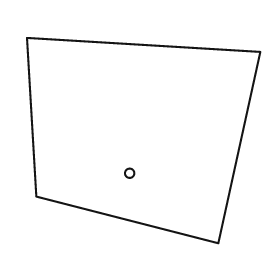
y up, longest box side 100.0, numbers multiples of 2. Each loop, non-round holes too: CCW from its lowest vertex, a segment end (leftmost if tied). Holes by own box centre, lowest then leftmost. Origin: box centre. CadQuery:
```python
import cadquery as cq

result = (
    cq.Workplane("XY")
    .moveTo(32.0, -44.0)
    .lineTo(50.0, 38.0)
    .lineTo(-50.0, 44.0)
    .lineTo(-46.0, -24.0)
    .close()
    .moveTo(-6.0, -14.0)
    .circle(2.0)
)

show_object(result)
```